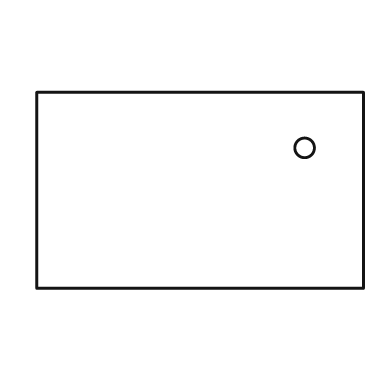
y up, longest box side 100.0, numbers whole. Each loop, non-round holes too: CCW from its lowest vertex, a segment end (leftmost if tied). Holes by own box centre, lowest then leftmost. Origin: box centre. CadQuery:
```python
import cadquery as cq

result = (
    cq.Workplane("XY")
    .moveTo(-50.0, -30.0)
    .lineTo(50.0, -30.0)
    .lineTo(50.0, 30.0)
    .lineTo(-50.0, 30.0)
    .close()
    .moveTo(32.0, 13.0)
    .circle(3.0)
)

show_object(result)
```